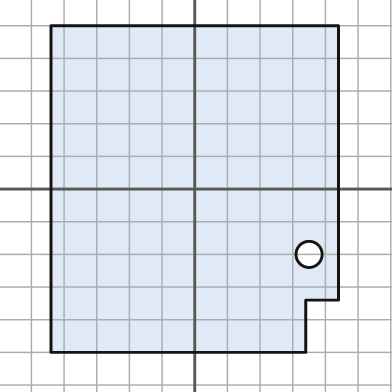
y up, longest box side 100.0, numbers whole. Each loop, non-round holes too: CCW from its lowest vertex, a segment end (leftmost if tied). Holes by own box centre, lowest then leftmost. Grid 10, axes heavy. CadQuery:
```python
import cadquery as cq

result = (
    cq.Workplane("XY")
    .moveTo(-44.0, -50.0)
    .lineTo(34.0, -50.0)
    .lineTo(34.0, -34.0)
    .lineTo(44.0, -34.0)
    .lineTo(44.0, 50.0)
    .lineTo(-44.0, 50.0)
    .close()
    .moveTo(35.0, -20.0)
    .circle(4.0)
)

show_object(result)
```